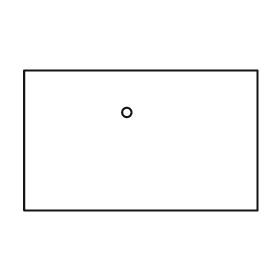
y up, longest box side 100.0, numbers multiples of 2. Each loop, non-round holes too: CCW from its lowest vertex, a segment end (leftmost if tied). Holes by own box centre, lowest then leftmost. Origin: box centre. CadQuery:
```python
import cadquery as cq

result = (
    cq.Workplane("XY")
    .moveTo(-50.0, -30.0)
    .lineTo(50.0, -30.0)
    .lineTo(50.0, 30.0)
    .lineTo(-50.0, 30.0)
    .close()
    .moveTo(-6.0, 12.0)
    .circle(2.0)
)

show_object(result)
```